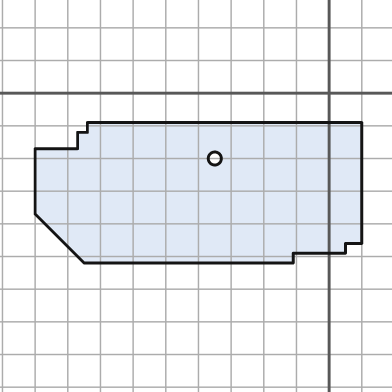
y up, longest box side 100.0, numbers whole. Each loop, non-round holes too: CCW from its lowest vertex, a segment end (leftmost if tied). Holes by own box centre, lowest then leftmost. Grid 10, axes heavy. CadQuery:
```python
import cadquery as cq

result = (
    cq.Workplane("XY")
    .moveTo(-75.0, -52.0)
    .lineTo(-11.0, -52.0)
    .lineTo(-11.0, -49.0)
    .lineTo(5.0, -49.0)
    .lineTo(5.0, -46.0)
    .lineTo(10.0, -46.0)
    .lineTo(10.0, -9.0)
    .lineTo(-74.0, -9.0)
    .lineTo(-74.0, -12.0)
    .lineTo(-77.0, -12.0)
    .lineTo(-77.0, -17.0)
    .lineTo(-90.0, -17.0)
    .lineTo(-90.0, -37.0)
    .close()
    .moveTo(-35.0, -20.0)
    .circle(2.0)
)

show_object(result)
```